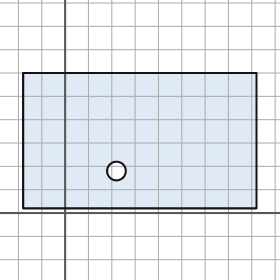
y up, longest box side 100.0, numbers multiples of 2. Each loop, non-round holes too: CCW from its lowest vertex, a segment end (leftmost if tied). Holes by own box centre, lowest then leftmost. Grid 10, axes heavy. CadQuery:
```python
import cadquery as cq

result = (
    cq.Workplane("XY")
    .moveTo(-18.0, 2.0)
    .lineTo(82.0, 2.0)
    .lineTo(82.0, 60.0)
    .lineTo(-18.0, 60.0)
    .close()
    .moveTo(22.0, 18.0)
    .circle(4.0)
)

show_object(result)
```